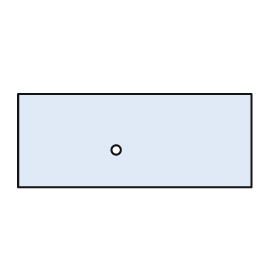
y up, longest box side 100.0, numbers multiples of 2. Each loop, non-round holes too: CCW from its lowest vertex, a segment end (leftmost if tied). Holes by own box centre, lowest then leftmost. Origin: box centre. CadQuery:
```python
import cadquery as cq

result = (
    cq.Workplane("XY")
    .moveTo(-50.0, -20.0)
    .lineTo(50.0, -20.0)
    .lineTo(50.0, 20.0)
    .lineTo(-50.0, 20.0)
    .close()
    .moveTo(-8.0, -4.0)
    .circle(2.0)
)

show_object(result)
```